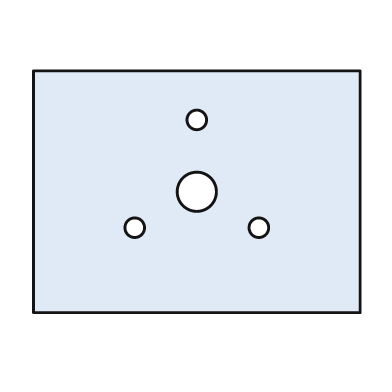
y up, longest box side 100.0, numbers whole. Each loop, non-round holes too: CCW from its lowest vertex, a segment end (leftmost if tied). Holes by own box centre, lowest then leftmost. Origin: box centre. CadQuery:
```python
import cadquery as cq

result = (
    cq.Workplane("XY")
    .moveTo(-50.0, -37.0)
    .lineTo(50.0, -37.0)
    .lineTo(50.0, 37.0)
    .lineTo(-50.0, 37.0)
    .close()
    .moveTo(-19.0, -11.0)
    .circle(3.0)
    .moveTo(19.0, -11.0)
    .circle(3.0)
    .moveTo(0.0, 0.0)
    .circle(6.0)
    .moveTo(0.0, 22.0)
    .circle(3.0)
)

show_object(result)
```